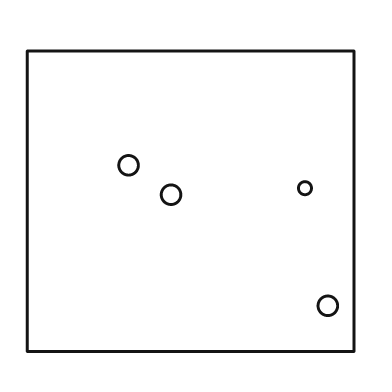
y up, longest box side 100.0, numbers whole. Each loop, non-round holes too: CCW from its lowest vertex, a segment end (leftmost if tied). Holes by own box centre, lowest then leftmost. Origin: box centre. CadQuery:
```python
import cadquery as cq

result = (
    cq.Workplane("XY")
    .moveTo(-50.0, -46.0)
    .lineTo(50.0, -46.0)
    .lineTo(50.0, 46.0)
    .lineTo(-50.0, 46.0)
    .close()
    .moveTo(42.0, -32.0)
    .circle(3.0)
    .moveTo(-6.0, 2.0)
    .circle(3.0)
    .moveTo(35.0, 4.0)
    .circle(2.0)
    .moveTo(-19.0, 11.0)
    .circle(3.0)
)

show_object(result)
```